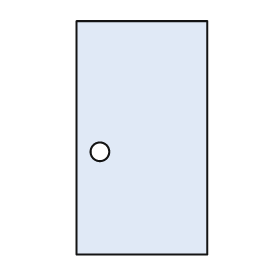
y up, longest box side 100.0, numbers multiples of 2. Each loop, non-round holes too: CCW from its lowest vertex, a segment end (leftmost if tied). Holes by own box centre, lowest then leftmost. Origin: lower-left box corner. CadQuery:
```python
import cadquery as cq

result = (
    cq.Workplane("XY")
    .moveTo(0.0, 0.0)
    .lineTo(56.0, 0.0)
    .lineTo(56.0, 100.0)
    .lineTo(0.0, 100.0)
    .close()
    .moveTo(10.0, 44.0)
    .circle(4.0)
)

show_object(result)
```